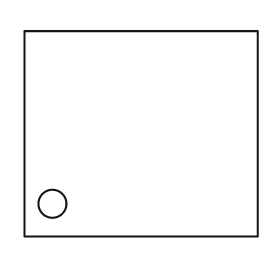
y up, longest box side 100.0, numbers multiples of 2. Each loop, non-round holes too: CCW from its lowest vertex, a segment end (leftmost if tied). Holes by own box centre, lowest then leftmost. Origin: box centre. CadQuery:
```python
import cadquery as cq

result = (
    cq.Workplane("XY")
    .moveTo(-50.0, -44.0)
    .lineTo(50.0, -44.0)
    .lineTo(50.0, 44.0)
    .lineTo(-50.0, 44.0)
    .close()
    .moveTo(-38.0, -30.0)
    .circle(6.0)
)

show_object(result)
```